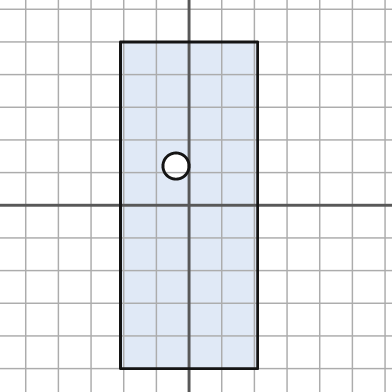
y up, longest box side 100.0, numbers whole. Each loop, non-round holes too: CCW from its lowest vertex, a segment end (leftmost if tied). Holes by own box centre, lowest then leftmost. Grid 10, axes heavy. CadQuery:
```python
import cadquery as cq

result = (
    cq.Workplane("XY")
    .moveTo(-21.0, -50.0)
    .lineTo(21.0, -50.0)
    .lineTo(21.0, 50.0)
    .lineTo(-21.0, 50.0)
    .close()
    .moveTo(-4.0, 12.0)
    .circle(4.0)
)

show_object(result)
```